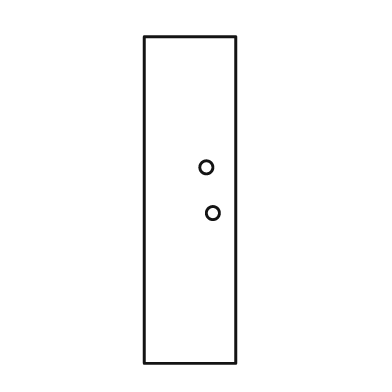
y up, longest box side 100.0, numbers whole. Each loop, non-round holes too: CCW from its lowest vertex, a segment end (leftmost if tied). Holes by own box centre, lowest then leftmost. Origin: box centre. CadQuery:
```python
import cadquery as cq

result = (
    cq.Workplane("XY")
    .moveTo(-14.0, -50.0)
    .lineTo(14.0, -50.0)
    .lineTo(14.0, 50.0)
    .lineTo(-14.0, 50.0)
    .close()
    .moveTo(7.0, -4.0)
    .circle(2.0)
    .moveTo(5.0, 10.0)
    .circle(2.0)
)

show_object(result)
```